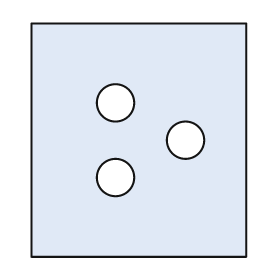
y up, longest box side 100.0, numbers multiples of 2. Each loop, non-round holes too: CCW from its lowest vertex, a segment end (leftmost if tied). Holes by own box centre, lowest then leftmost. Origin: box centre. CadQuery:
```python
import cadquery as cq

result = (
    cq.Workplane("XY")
    .moveTo(-46.0, -50.0)
    .lineTo(46.0, -50.0)
    .lineTo(46.0, 50.0)
    .lineTo(-46.0, 50.0)
    .close()
    .moveTo(-10.0, -16.0)
    .circle(8.0)
    .moveTo(20.0, 0.0)
    .circle(8.0)
    .moveTo(-10.0, 16.0)
    .circle(8.0)
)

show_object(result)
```